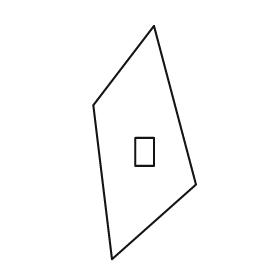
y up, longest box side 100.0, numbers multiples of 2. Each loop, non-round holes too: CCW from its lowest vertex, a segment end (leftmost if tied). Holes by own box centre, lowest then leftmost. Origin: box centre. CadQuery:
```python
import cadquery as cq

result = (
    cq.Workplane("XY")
    .moveTo(-14.0, -50.0)
    .lineTo(22.0, -18.0)
    .lineTo(4.0, 50.0)
    .lineTo(-22.0, 16.0)
    .close()
    .moveTo(-4.0, -10.0)
    .lineTo(4.0, -10.0)
    .lineTo(4.0, 2.0)
    .lineTo(-4.0, 2.0)
    .close()
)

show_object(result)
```